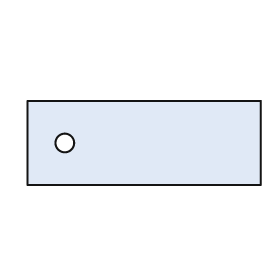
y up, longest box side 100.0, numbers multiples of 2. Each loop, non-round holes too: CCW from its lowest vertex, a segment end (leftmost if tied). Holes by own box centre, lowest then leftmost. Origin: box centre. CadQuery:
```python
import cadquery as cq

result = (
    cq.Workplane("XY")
    .moveTo(-50.0, -18.0)
    .lineTo(50.0, -18.0)
    .lineTo(50.0, 18.0)
    .lineTo(-50.0, 18.0)
    .close()
    .moveTo(-34.0, 0.0)
    .circle(4.0)
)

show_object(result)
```